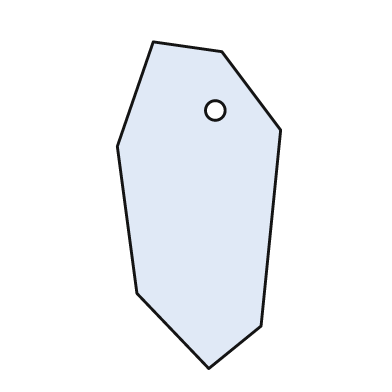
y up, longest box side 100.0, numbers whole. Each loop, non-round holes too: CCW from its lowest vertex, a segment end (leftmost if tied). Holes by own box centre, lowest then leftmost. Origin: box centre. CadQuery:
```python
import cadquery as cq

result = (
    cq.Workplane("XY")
    .moveTo(3.0, -50.0)
    .lineTo(19.0, -37.0)
    .lineTo(25.0, 23.0)
    .lineTo(7.0, 47.0)
    .lineTo(-14.0, 50.0)
    .lineTo(-25.0, 18.0)
    .lineTo(-19.0, -27.0)
    .close()
    .moveTo(5.0, 29.0)
    .circle(3.0)
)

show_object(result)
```